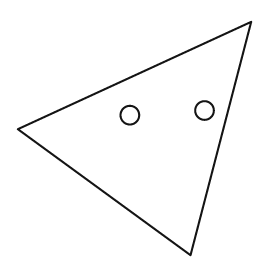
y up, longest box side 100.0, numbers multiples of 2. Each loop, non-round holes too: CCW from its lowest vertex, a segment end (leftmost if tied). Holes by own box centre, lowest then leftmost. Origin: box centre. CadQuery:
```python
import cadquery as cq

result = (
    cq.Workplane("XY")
    .moveTo(24.0, -50.0)
    .lineTo(50.0, 50.0)
    .lineTo(-50.0, 4.0)
    .close()
    .moveTo(-2.0, 10.0)
    .circle(4.0)
    .moveTo(30.0, 12.0)
    .circle(4.0)
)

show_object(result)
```